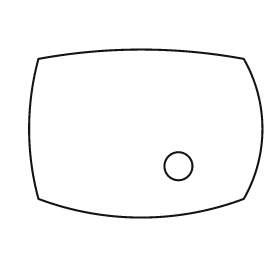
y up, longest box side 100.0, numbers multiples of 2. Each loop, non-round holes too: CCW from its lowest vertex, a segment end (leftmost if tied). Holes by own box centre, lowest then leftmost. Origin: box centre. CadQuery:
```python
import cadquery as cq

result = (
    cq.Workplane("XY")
    .moveTo(-46.0, -28.0)
    .threePointArc((-2.0, -36.0), (42.0, -28.0))
    .threePointArc((50.0, 2.0), (42.0, 32.0))
    .threePointArc((-2.0, 36.0), (-46.0, 32.0))
    .threePointArc((-50.0, 2.0), (-46.0, -28.0))
    .close()
    .moveTo(14.0, -14.0)
    .circle(6.0)
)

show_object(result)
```